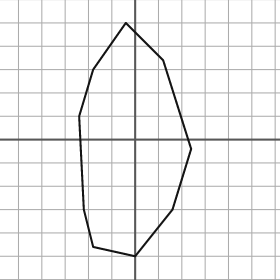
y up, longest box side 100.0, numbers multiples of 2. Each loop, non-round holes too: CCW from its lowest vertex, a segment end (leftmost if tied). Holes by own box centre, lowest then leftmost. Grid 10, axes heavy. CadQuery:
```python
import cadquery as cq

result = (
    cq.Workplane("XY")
    .moveTo(0.0, -50.0)
    .lineTo(16.0, -30.0)
    .lineTo(24.0, -4.0)
    .lineTo(12.0, 34.0)
    .lineTo(-4.0, 50.0)
    .lineTo(-18.0, 30.0)
    .lineTo(-24.0, 10.0)
    .lineTo(-22.0, -30.0)
    .lineTo(-18.0, -46.0)
    .close()
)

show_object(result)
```